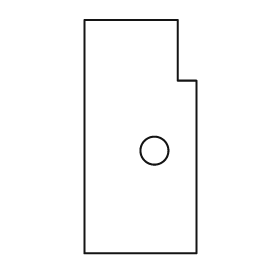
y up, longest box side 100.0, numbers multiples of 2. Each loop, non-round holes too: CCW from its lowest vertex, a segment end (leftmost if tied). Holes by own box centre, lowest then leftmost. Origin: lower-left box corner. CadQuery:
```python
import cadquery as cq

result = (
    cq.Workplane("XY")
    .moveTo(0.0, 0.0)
    .lineTo(48.0, 0.0)
    .lineTo(48.0, 74.0)
    .lineTo(40.0, 74.0)
    .lineTo(40.0, 100.0)
    .lineTo(0.0, 100.0)
    .close()
    .moveTo(30.0, 44.0)
    .circle(6.0)
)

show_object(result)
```